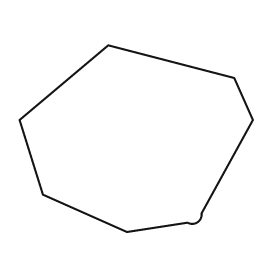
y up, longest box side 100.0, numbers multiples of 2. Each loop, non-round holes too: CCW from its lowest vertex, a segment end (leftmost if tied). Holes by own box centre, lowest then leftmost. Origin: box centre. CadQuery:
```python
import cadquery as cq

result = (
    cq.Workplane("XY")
    .moveTo(-4.0, -40.0)
    .lineTo(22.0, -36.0)
    .threePointArc((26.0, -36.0), (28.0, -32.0))
    .lineTo(50.0, 8.0)
    .lineTo(42.0, 26.0)
    .lineTo(-12.0, 40.0)
    .lineTo(-50.0, 8.0)
    .lineTo(-40.0, -24.0)
    .close()
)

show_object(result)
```